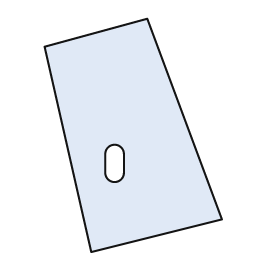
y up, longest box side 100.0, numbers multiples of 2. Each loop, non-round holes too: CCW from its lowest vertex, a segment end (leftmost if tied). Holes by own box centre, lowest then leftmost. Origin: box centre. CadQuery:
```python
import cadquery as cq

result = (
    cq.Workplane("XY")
    .moveTo(-18.0, -50.0)
    .lineTo(38.0, -36.0)
    .lineTo(6.0, 50.0)
    .lineTo(-38.0, 38.0)
    .close()
    .moveTo(-12.0, -16.0)
    .threePointArc((-8.0, -20.0), (-4.0, -16.0))
    .lineTo(-4.0, -8.0)
    .threePointArc((-8.0, -4.0), (-12.0, -8.0))
    .close()
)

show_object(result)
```